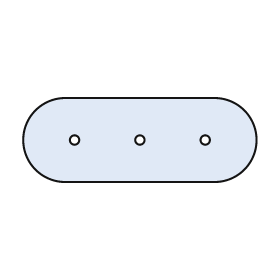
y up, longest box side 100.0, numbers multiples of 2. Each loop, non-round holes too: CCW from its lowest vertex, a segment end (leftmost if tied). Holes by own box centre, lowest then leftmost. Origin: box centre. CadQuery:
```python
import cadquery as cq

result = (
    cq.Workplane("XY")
    .moveTo(-32.0, -18.0)
    .lineTo(32.0, -18.0)
    .threePointArc((50.0, 0.0), (32.0, 18.0))
    .lineTo(-32.0, 18.0)
    .threePointArc((-50.0, 0.0), (-32.0, -18.0))
    .close()
    .moveTo(-28.0, 0.0)
    .circle(2.0)
    .moveTo(0.0, 0.0)
    .circle(2.0)
    .moveTo(28.0, 0.0)
    .circle(2.0)
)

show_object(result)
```